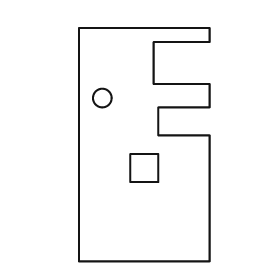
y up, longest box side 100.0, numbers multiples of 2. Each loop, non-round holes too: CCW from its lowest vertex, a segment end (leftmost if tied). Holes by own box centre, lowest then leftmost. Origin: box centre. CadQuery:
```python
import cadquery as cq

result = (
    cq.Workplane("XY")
    .moveTo(-28.0, -50.0)
    .lineTo(28.0, -50.0)
    .lineTo(28.0, 4.0)
    .lineTo(6.0, 4.0)
    .lineTo(6.0, 16.0)
    .lineTo(28.0, 16.0)
    .lineTo(28.0, 26.0)
    .lineTo(4.0, 26.0)
    .lineTo(4.0, 44.0)
    .lineTo(28.0, 44.0)
    .lineTo(28.0, 50.0)
    .lineTo(-28.0, 50.0)
    .close()
    .moveTo(-6.0, -16.0)
    .lineTo(6.0, -16.0)
    .lineTo(6.0, -4.0)
    .lineTo(-6.0, -4.0)
    .close()
    .moveTo(-18.0, 20.0)
    .circle(4.0)
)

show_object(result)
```